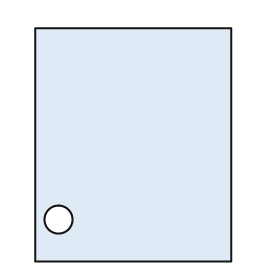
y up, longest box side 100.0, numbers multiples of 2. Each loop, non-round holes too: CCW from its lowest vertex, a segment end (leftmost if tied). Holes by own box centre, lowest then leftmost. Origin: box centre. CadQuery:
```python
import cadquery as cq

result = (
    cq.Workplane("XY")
    .moveTo(-42.0, -50.0)
    .lineTo(42.0, -50.0)
    .lineTo(42.0, 50.0)
    .lineTo(-42.0, 50.0)
    .close()
    .moveTo(-32.0, -32.0)
    .circle(6.0)
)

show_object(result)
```